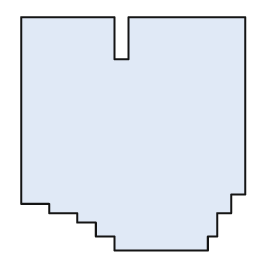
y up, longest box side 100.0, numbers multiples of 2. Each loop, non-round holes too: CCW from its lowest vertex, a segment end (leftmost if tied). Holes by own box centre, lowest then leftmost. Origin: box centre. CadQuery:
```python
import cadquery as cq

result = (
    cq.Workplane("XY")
    .moveTo(-8.0, -50.0)
    .lineTo(32.0, -50.0)
    .lineTo(32.0, -44.0)
    .lineTo(36.0, -44.0)
    .lineTo(36.0, -34.0)
    .lineTo(42.0, -34.0)
    .lineTo(42.0, -26.0)
    .lineTo(48.0, -26.0)
    .lineTo(48.0, 50.0)
    .lineTo(-2.0, 50.0)
    .lineTo(-2.0, 32.0)
    .lineTo(-8.0, 32.0)
    .lineTo(-8.0, 50.0)
    .lineTo(-48.0, 50.0)
    .lineTo(-48.0, -30.0)
    .lineTo(-36.0, -30.0)
    .lineTo(-36.0, -34.0)
    .lineTo(-24.0, -34.0)
    .lineTo(-24.0, -38.0)
    .lineTo(-16.0, -38.0)
    .lineTo(-16.0, -44.0)
    .lineTo(-8.0, -44.0)
    .close()
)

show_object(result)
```